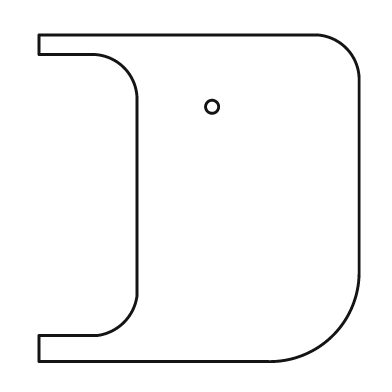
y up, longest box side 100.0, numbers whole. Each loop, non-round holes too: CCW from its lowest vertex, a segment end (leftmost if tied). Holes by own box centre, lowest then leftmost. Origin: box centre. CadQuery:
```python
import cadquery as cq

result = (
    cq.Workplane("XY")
    .moveTo(-49.0, -50.0)
    .lineTo(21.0, -50.0)
    .threePointArc((41.0, -42.0), (49.0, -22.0))
    .lineTo(49.0, 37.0)
    .threePointArc((45.0, 46.0), (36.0, 50.0))
    .lineTo(-49.0, 50.0)
    .lineTo(-49.0, 44.0)
    .lineTo(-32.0, 44.0)
    .threePointArc((-23.0, 40.0), (-19.0, 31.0))
    .lineTo(-19.0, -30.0)
    .threePointArc((-23.0, -38.0), (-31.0, -42.0))
    .lineTo(-49.0, -42.0)
    .close()
    .moveTo(4.0, 28.0)
    .circle(2.0)
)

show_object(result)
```